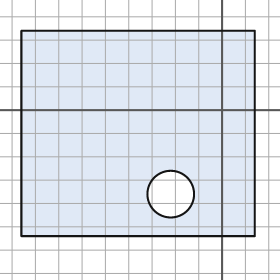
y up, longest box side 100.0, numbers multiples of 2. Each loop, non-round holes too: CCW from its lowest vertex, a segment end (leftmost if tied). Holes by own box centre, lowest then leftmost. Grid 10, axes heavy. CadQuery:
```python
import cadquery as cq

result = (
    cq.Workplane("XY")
    .moveTo(-86.0, -54.0)
    .lineTo(14.0, -54.0)
    .lineTo(14.0, 34.0)
    .lineTo(-86.0, 34.0)
    .close()
    .moveTo(-22.0, -36.0)
    .circle(10.0)
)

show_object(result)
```